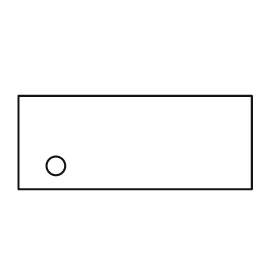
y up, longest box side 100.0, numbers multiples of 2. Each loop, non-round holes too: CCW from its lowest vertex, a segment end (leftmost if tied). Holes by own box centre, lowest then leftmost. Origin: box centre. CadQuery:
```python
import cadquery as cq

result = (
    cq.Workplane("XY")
    .moveTo(-50.0, -20.0)
    .lineTo(50.0, -20.0)
    .lineTo(50.0, 20.0)
    .lineTo(-50.0, 20.0)
    .close()
    .moveTo(-34.0, -10.0)
    .circle(4.0)
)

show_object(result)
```